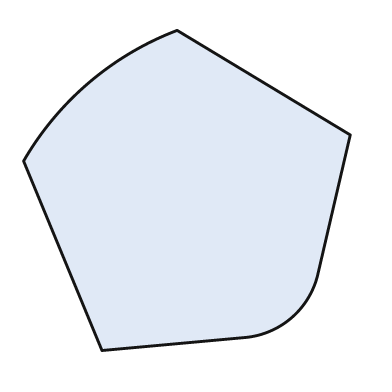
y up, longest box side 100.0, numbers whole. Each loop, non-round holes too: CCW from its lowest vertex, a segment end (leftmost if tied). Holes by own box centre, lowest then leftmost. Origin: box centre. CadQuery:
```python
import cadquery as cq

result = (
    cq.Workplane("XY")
    .moveTo(-26.0, -49.0)
    .lineTo(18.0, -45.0)
    .threePointArc((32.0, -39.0), (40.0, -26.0))
    .lineTo(50.0, 17.0)
    .lineTo(-3.0, 49.0)
    .threePointArc((-30.0, 33.0), (-50.0, 9.0))
    .close()
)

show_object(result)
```